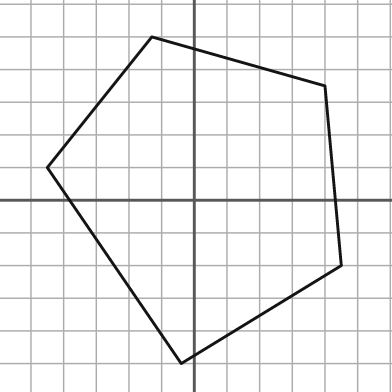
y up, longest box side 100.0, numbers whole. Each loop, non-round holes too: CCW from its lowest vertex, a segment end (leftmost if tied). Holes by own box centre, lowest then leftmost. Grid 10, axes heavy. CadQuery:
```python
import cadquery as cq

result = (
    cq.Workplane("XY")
    .moveTo(-4.0, -50.0)
    .lineTo(45.0, -20.0)
    .lineTo(40.0, 35.0)
    .lineTo(-13.0, 50.0)
    .lineTo(-45.0, 10.0)
    .close()
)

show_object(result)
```